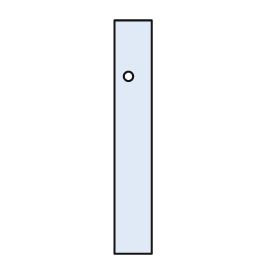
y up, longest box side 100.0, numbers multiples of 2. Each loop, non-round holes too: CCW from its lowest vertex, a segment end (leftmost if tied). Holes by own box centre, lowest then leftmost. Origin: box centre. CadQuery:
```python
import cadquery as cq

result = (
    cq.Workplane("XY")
    .moveTo(-8.0, -50.0)
    .lineTo(8.0, -50.0)
    .lineTo(8.0, 50.0)
    .lineTo(-8.0, 50.0)
    .close()
    .moveTo(-2.0, 26.0)
    .circle(2.0)
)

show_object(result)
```